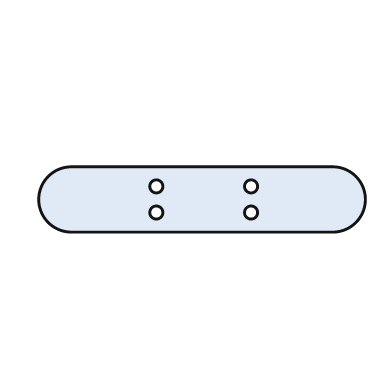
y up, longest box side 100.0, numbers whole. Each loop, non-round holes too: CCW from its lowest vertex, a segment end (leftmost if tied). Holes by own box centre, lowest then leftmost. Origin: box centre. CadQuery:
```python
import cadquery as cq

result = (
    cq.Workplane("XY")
    .moveTo(-40.0, -10.0)
    .lineTo(40.0, -10.0)
    .threePointArc((50.0, 0.0), (40.0, 10.0))
    .lineTo(-40.0, 10.0)
    .threePointArc((-50.0, 0.0), (-40.0, -10.0))
    .close()
    .moveTo(-14.0, -4.0)
    .circle(2.0)
    .moveTo(15.0, -4.0)
    .circle(2.0)
    .moveTo(-14.0, 4.0)
    .circle(2.0)
    .moveTo(15.0, 4.0)
    .circle(2.0)
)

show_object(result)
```